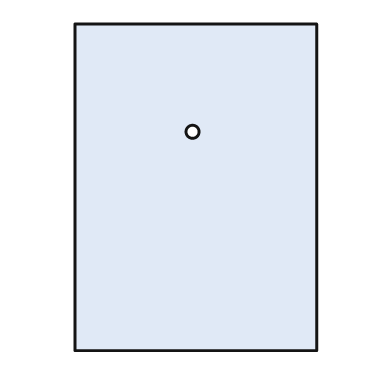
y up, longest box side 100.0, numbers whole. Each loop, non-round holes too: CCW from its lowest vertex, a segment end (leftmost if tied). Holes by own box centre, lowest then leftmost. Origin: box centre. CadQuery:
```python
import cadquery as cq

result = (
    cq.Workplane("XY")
    .moveTo(-37.0, -50.0)
    .lineTo(37.0, -50.0)
    .lineTo(37.0, 50.0)
    .lineTo(-37.0, 50.0)
    .close()
    .moveTo(-1.0, 17.0)
    .circle(2.0)
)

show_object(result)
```